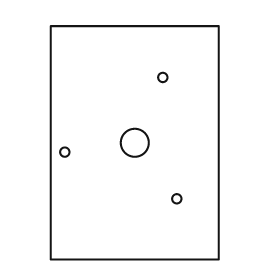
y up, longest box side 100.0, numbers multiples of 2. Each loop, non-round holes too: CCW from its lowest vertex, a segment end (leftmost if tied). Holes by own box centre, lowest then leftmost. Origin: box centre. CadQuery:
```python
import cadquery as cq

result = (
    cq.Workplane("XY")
    .moveTo(-36.0, -50.0)
    .lineTo(36.0, -50.0)
    .lineTo(36.0, 50.0)
    .lineTo(-36.0, 50.0)
    .close()
    .moveTo(18.0, -24.0)
    .circle(2.0)
    .moveTo(-30.0, -4.0)
    .circle(2.0)
    .moveTo(0.0, 0.0)
    .circle(6.0)
    .moveTo(12.0, 28.0)
    .circle(2.0)
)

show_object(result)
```